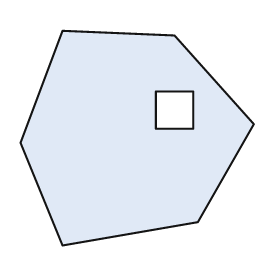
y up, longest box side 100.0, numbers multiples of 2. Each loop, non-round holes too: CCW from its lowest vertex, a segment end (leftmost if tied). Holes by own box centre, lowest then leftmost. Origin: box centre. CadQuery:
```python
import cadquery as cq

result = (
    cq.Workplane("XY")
    .moveTo(-32.0, -46.0)
    .lineTo(26.0, -36.0)
    .lineTo(50.0, 6.0)
    .lineTo(16.0, 44.0)
    .lineTo(-32.0, 46.0)
    .lineTo(-50.0, -2.0)
    .close()
    .moveTo(8.0, 4.0)
    .lineTo(24.0, 4.0)
    .lineTo(24.0, 20.0)
    .lineTo(8.0, 20.0)
    .close()
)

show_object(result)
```